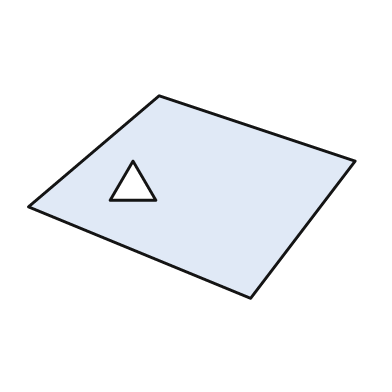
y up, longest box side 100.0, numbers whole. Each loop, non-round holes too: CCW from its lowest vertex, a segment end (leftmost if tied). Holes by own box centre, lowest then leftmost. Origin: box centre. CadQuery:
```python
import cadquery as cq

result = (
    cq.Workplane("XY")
    .moveTo(18.0, -31.0)
    .lineTo(50.0, 11.0)
    .lineTo(-10.0, 31.0)
    .lineTo(-50.0, -3.0)
    .close()
    .moveTo(-25.0, -1.0)
    .lineTo(-11.0, -1.0)
    .lineTo(-18.0, 11.0)
    .close()
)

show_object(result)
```